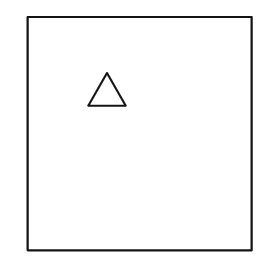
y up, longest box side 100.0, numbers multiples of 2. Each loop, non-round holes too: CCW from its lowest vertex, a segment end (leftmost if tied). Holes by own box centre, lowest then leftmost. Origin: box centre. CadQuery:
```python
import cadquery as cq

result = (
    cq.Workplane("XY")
    .moveTo(-48.0, -50.0)
    .lineTo(48.0, -50.0)
    .lineTo(48.0, 50.0)
    .lineTo(-48.0, 50.0)
    .close()
    .moveTo(-22.0, 12.0)
    .lineTo(-6.0, 12.0)
    .lineTo(-14.0, 26.0)
    .close()
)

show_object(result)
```